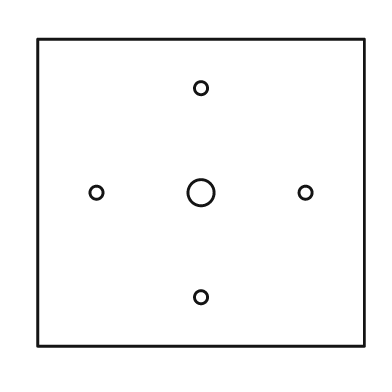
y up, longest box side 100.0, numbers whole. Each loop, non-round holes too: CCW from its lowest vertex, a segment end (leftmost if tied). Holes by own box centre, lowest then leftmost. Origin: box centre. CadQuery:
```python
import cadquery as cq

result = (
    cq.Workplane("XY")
    .moveTo(-50.0, -47.0)
    .lineTo(50.0, -47.0)
    .lineTo(50.0, 47.0)
    .lineTo(-50.0, 47.0)
    .close()
    .moveTo(0.0, -32.0)
    .circle(2.0)
    .moveTo(-32.0, 0.0)
    .circle(2.0)
    .moveTo(0.0, 0.0)
    .circle(4.0)
    .moveTo(32.0, 0.0)
    .circle(2.0)
    .moveTo(0.0, 32.0)
    .circle(2.0)
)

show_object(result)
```